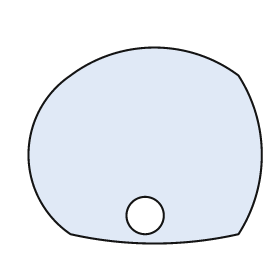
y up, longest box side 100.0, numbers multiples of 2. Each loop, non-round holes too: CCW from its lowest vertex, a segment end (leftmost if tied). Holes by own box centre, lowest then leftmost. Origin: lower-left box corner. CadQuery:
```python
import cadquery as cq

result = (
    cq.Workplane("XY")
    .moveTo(18.0, 4.0)
    .threePointArc((54.0, 0.0), (90.0, 4.0))
    .threePointArc((100.0, 38.0), (90.0, 72.0))
    .threePointArc((54.0, 84.0), (18.0, 72.0))
    .threePointArc((0.0, 38.0), (18.0, 4.0))
    .close()
    .moveTo(50.0, 12.0)
    .circle(8.0)
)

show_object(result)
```